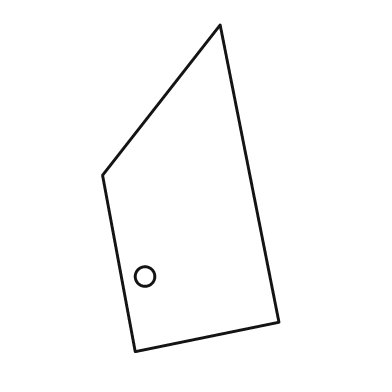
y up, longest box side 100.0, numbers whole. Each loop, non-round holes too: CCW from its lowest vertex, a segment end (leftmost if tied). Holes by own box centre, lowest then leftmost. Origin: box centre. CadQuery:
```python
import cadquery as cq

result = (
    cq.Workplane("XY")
    .moveTo(-17.0, -50.0)
    .lineTo(27.0, -41.0)
    .lineTo(9.0, 50.0)
    .lineTo(-27.0, 4.0)
    .close()
    .moveTo(-14.0, -27.0)
    .circle(3.0)
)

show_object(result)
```